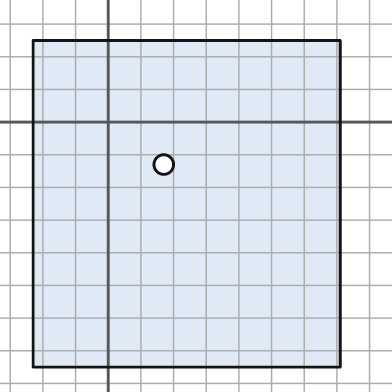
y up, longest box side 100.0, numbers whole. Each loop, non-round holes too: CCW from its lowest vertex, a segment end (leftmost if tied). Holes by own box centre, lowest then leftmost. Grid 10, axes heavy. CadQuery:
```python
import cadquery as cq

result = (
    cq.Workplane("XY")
    .moveTo(-23.0, -75.0)
    .lineTo(71.0, -75.0)
    .lineTo(71.0, 25.0)
    .lineTo(-23.0, 25.0)
    .close()
    .moveTo(17.0, -13.0)
    .circle(3.0)
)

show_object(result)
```